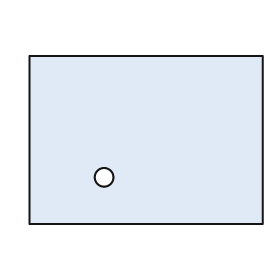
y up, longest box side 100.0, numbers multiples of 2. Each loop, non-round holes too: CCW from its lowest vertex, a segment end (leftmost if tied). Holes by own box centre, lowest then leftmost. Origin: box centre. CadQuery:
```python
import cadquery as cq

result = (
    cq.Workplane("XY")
    .moveTo(-50.0, -36.0)
    .lineTo(50.0, -36.0)
    .lineTo(50.0, 36.0)
    .lineTo(-50.0, 36.0)
    .close()
    .moveTo(-18.0, -16.0)
    .circle(4.0)
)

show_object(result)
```